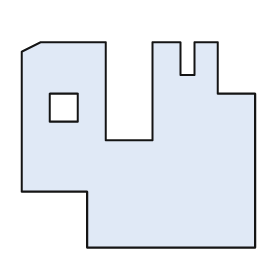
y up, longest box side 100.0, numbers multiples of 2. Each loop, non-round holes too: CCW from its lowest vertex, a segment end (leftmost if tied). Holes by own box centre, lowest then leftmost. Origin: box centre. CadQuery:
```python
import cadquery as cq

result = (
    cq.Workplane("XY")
    .moveTo(-22.0, -44.0)
    .lineTo(50.0, -44.0)
    .lineTo(50.0, 22.0)
    .lineTo(34.0, 22.0)
    .lineTo(34.0, 44.0)
    .lineTo(24.0, 44.0)
    .lineTo(24.0, 30.0)
    .lineTo(18.0, 30.0)
    .lineTo(18.0, 44.0)
    .lineTo(6.0, 44.0)
    .lineTo(6.0, 2.0)
    .lineTo(-14.0, 2.0)
    .lineTo(-14.0, 44.0)
    .lineTo(-42.0, 44.0)
    .lineTo(-50.0, 40.0)
    .lineTo(-50.0, -20.0)
    .lineTo(-22.0, -20.0)
    .close()
    .moveTo(-38.0, 10.0)
    .lineTo(-26.0, 10.0)
    .lineTo(-26.0, 22.0)
    .lineTo(-38.0, 22.0)
    .close()
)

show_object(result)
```